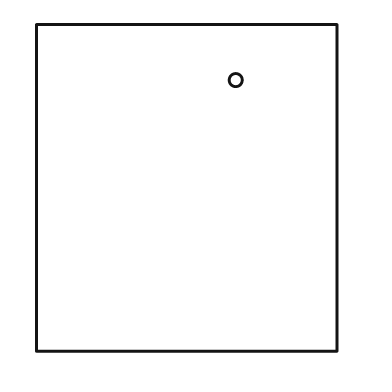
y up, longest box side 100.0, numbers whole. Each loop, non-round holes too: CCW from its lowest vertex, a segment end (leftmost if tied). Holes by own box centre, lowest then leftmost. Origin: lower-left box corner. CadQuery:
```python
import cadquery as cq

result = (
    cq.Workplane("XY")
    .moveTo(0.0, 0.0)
    .lineTo(92.0, 0.0)
    .lineTo(92.0, 100.0)
    .lineTo(0.0, 100.0)
    .close()
    .moveTo(61.0, 83.0)
    .circle(2.0)
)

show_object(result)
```